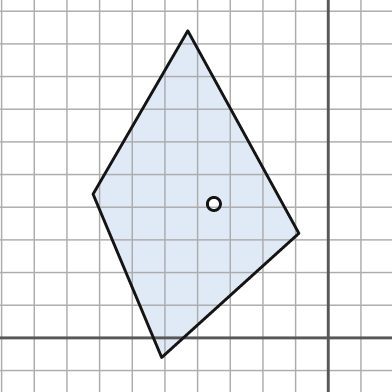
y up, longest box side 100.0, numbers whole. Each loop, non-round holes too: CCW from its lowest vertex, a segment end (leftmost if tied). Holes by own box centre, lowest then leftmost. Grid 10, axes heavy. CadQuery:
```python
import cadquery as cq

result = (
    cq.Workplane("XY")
    .moveTo(-51.0, -6.0)
    .lineTo(-9.0, 32.0)
    .lineTo(-43.0, 94.0)
    .lineTo(-72.0, 44.0)
    .close()
    .moveTo(-35.0, 41.0)
    .circle(2.0)
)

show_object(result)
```